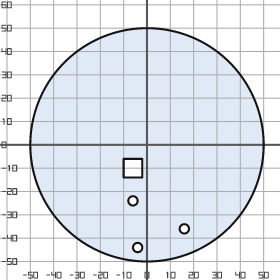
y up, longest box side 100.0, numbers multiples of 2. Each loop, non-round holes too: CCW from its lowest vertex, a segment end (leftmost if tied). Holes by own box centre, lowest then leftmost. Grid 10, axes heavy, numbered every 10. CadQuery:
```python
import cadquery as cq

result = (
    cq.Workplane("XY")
    .moveTo(0.0, 0.0)
    .circle(50.0)
    .moveTo(-4.0, -44.0)
    .circle(2.0)
    .moveTo(16.0, -36.0)
    .circle(2.0)
    .moveTo(-6.0, -24.0)
    .circle(2.0)
    .moveTo(-10.0, -14.0)
    .lineTo(-2.0, -14.0)
    .lineTo(-2.0, -6.0)
    .lineTo(-10.0, -6.0)
    .close()
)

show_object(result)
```